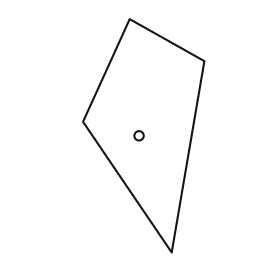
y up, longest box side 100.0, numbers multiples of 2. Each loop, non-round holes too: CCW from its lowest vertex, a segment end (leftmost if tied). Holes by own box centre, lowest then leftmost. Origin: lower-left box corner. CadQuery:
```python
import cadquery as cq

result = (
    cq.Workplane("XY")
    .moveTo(38.0, 0.0)
    .lineTo(52.0, 82.0)
    .lineTo(20.0, 100.0)
    .lineTo(0.0, 56.0)
    .close()
    .moveTo(24.0, 50.0)
    .circle(2.0)
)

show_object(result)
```